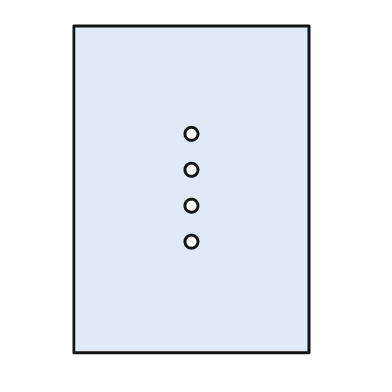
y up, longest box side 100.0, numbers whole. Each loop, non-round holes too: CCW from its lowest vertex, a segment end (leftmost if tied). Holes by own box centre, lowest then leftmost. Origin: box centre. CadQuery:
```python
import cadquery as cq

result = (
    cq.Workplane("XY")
    .moveTo(-36.0, -50.0)
    .lineTo(36.0, -50.0)
    .lineTo(36.0, 50.0)
    .lineTo(-36.0, 50.0)
    .close()
    .moveTo(0.0, -16.0)
    .circle(2.0)
    .moveTo(0.0, -5.0)
    .circle(2.0)
    .moveTo(0.0, 6.0)
    .circle(2.0)
    .moveTo(0.0, 17.0)
    .circle(2.0)
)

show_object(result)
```